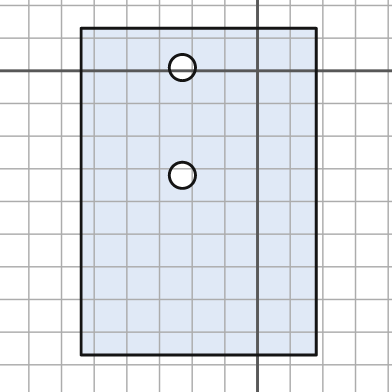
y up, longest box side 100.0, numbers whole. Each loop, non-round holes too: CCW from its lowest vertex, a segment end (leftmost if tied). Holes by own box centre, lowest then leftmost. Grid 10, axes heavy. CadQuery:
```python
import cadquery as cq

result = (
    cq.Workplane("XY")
    .moveTo(-54.0, -87.0)
    .lineTo(18.0, -87.0)
    .lineTo(18.0, 13.0)
    .lineTo(-54.0, 13.0)
    .close()
    .moveTo(-23.0, -32.0)
    .circle(4.0)
    .moveTo(-23.0, 1.0)
    .circle(4.0)
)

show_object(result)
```